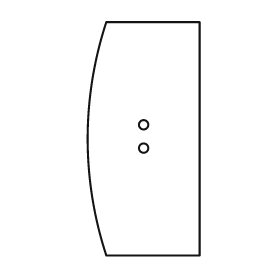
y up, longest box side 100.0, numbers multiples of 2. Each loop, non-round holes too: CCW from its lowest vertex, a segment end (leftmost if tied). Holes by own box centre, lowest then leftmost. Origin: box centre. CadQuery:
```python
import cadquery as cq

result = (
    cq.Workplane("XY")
    .moveTo(-16.0, -50.0)
    .lineTo(24.0, -50.0)
    .lineTo(24.0, 50.0)
    .lineTo(-16.0, 50.0)
    .threePointArc((-24.0, 0.0), (-16.0, -50.0))
    .close()
    .moveTo(0.0, -4.0)
    .circle(2.0)
    .moveTo(0.0, 6.0)
    .circle(2.0)
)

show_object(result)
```